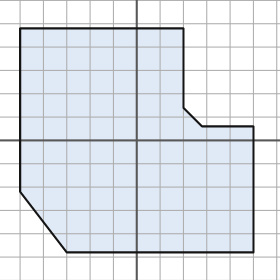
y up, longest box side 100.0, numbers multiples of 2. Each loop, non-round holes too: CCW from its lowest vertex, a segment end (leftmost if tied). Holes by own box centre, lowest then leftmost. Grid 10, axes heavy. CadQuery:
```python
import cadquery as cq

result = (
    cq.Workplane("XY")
    .moveTo(-30.0, -48.0)
    .lineTo(50.0, -48.0)
    .lineTo(50.0, 6.0)
    .lineTo(28.0, 6.0)
    .lineTo(20.0, 14.0)
    .lineTo(20.0, 48.0)
    .lineTo(-50.0, 48.0)
    .lineTo(-50.0, -22.0)
    .close()
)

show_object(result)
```